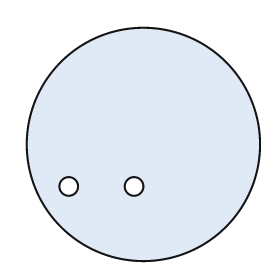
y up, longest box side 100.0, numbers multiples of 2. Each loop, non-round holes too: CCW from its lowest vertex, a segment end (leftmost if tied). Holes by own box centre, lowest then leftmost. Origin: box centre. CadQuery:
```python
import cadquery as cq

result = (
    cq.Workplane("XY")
    .moveTo(0.0, 0.0)
    .circle(50.0)
    .moveTo(-32.0, -18.0)
    .circle(4.0)
    .moveTo(-4.0, -18.0)
    .circle(4.0)
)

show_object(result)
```